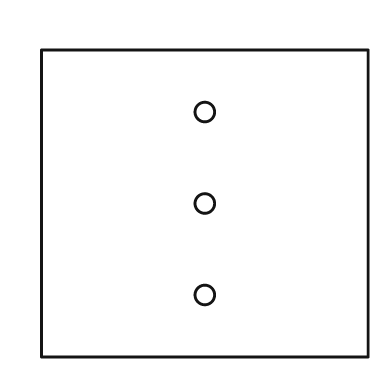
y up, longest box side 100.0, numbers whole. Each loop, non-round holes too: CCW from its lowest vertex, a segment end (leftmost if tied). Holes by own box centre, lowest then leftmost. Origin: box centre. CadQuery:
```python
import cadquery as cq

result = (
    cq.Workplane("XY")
    .moveTo(-50.0, -47.0)
    .lineTo(50.0, -47.0)
    .lineTo(50.0, 47.0)
    .lineTo(-50.0, 47.0)
    .close()
    .moveTo(0.0, -28.0)
    .circle(3.0)
    .moveTo(0.0, 0.0)
    .circle(3.0)
    .moveTo(0.0, 28.0)
    .circle(3.0)
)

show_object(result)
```